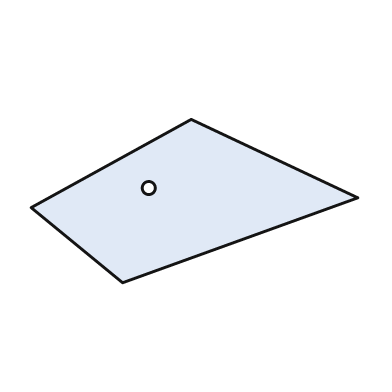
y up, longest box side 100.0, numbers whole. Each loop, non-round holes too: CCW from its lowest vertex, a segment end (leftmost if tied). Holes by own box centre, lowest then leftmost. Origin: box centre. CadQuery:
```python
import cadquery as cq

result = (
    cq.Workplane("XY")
    .moveTo(-22.0, -25.0)
    .lineTo(50.0, 1.0)
    .lineTo(-1.0, 25.0)
    .lineTo(-50.0, -2.0)
    .close()
    .moveTo(-14.0, 4.0)
    .circle(2.0)
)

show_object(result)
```